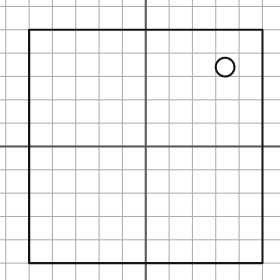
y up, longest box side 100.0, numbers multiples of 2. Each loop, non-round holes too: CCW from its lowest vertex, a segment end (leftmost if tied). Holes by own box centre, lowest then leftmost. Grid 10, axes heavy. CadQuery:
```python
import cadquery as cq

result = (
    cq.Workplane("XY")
    .moveTo(-50.0, -50.0)
    .lineTo(50.0, -50.0)
    .lineTo(50.0, 50.0)
    .lineTo(-50.0, 50.0)
    .close()
    .moveTo(34.0, 34.0)
    .circle(4.0)
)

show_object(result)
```